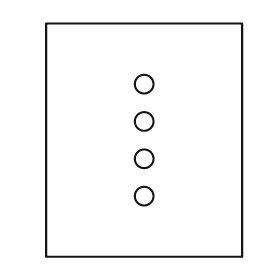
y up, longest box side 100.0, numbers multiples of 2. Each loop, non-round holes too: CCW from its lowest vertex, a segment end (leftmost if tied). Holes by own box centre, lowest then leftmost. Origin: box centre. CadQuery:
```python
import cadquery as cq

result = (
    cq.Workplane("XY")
    .moveTo(-42.0, -50.0)
    .lineTo(42.0, -50.0)
    .lineTo(42.0, 50.0)
    .lineTo(-42.0, 50.0)
    .close()
    .moveTo(0.0, -24.0)
    .circle(4.0)
    .moveTo(0.0, -8.0)
    .circle(4.0)
    .moveTo(0.0, 8.0)
    .circle(4.0)
    .moveTo(0.0, 24.0)
    .circle(4.0)
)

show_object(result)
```